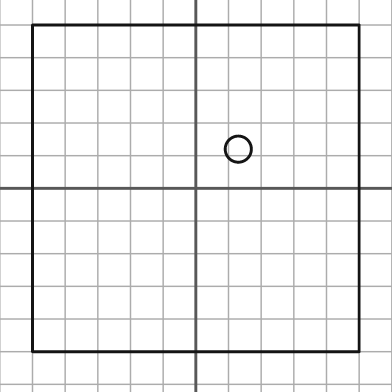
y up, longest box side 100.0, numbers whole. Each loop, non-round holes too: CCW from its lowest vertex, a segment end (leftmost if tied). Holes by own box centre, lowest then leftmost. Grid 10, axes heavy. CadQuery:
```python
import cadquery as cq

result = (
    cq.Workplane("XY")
    .moveTo(-50.0, -50.0)
    .lineTo(50.0, -50.0)
    .lineTo(50.0, 50.0)
    .lineTo(-50.0, 50.0)
    .close()
    .moveTo(13.0, 12.0)
    .circle(4.0)
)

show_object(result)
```